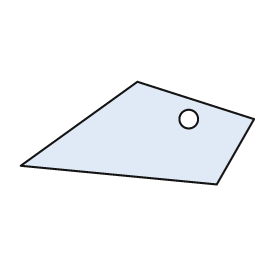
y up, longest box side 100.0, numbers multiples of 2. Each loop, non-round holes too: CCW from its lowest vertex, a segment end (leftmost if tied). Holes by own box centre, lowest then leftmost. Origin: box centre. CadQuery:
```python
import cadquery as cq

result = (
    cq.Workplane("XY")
    .moveTo(34.0, -22.0)
    .lineTo(50.0, 6.0)
    .lineTo(0.0, 22.0)
    .lineTo(-50.0, -14.0)
    .close()
    .moveTo(22.0, 6.0)
    .circle(4.0)
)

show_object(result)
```